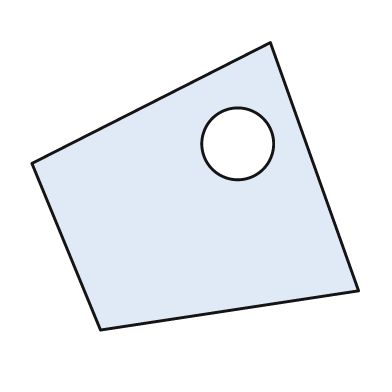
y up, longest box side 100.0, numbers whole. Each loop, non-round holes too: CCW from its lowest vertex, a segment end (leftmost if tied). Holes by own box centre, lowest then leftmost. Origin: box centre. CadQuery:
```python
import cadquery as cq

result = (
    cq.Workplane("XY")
    .moveTo(-29.0, -44.0)
    .lineTo(50.0, -32.0)
    .lineTo(23.0, 44.0)
    .lineTo(-50.0, 7.0)
    .close()
    .moveTo(13.0, 13.0)
    .circle(11.0)
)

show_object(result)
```